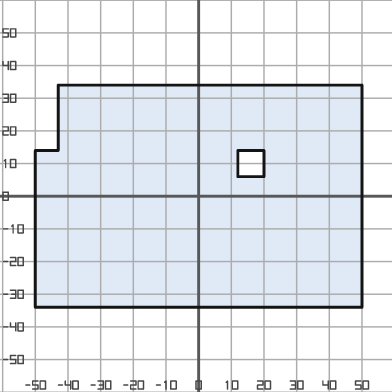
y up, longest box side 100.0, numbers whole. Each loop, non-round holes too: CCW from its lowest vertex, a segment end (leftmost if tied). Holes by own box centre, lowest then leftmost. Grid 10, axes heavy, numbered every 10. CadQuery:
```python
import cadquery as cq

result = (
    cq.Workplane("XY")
    .moveTo(-50.0, -34.0)
    .lineTo(50.0, -34.0)
    .lineTo(50.0, 34.0)
    .lineTo(-43.0, 34.0)
    .lineTo(-43.0, 14.0)
    .lineTo(-50.0, 14.0)
    .close()
    .moveTo(12.0, 6.0)
    .lineTo(20.0, 6.0)
    .lineTo(20.0, 14.0)
    .lineTo(12.0, 14.0)
    .close()
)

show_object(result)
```